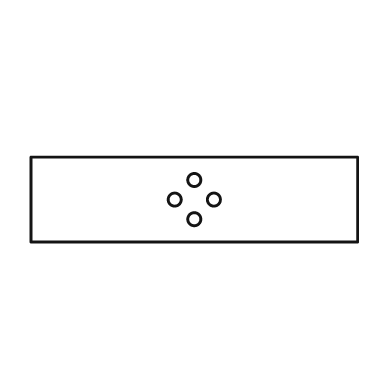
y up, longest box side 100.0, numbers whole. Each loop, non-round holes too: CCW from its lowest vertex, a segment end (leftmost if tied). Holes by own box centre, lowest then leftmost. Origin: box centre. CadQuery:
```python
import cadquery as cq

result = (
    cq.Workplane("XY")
    .moveTo(-50.0, -13.0)
    .lineTo(50.0, -13.0)
    .lineTo(50.0, 13.0)
    .lineTo(-50.0, 13.0)
    .close()
    .moveTo(0.0, -6.0)
    .circle(2.0)
    .moveTo(-6.0, 0.0)
    .circle(2.0)
    .moveTo(6.0, 0.0)
    .circle(2.0)
    .moveTo(0.0, 6.0)
    .circle(2.0)
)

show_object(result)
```